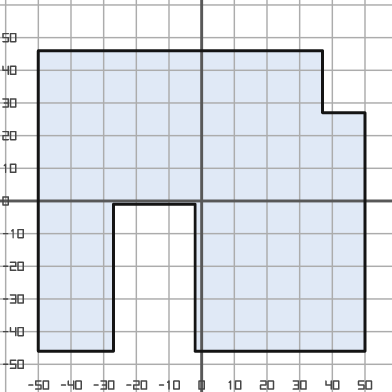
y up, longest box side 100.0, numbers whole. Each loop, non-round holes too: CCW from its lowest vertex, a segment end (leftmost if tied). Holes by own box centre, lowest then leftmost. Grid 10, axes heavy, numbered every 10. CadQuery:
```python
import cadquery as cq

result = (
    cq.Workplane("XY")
    .moveTo(-50.0, -46.0)
    .lineTo(-27.0, -46.0)
    .lineTo(-27.0, -1.0)
    .lineTo(-2.0, -1.0)
    .lineTo(-2.0, -46.0)
    .lineTo(50.0, -46.0)
    .lineTo(50.0, 27.0)
    .lineTo(37.0, 27.0)
    .lineTo(37.0, 46.0)
    .lineTo(-50.0, 46.0)
    .close()
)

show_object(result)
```